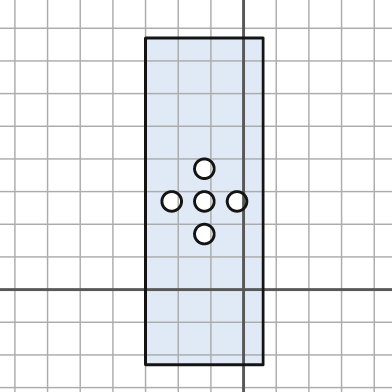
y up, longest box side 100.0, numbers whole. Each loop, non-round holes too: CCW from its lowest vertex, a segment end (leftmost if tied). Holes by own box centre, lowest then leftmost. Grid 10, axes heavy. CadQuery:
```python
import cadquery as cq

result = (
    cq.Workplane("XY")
    .moveTo(-30.0, -23.0)
    .lineTo(6.0, -23.0)
    .lineTo(6.0, 77.0)
    .lineTo(-30.0, 77.0)
    .close()
    .moveTo(-12.0, 17.0)
    .circle(3.0)
    .moveTo(-22.0, 27.0)
    .circle(3.0)
    .moveTo(-12.0, 27.0)
    .circle(3.0)
    .moveTo(-2.0, 27.0)
    .circle(3.0)
    .moveTo(-12.0, 37.0)
    .circle(3.0)
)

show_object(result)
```